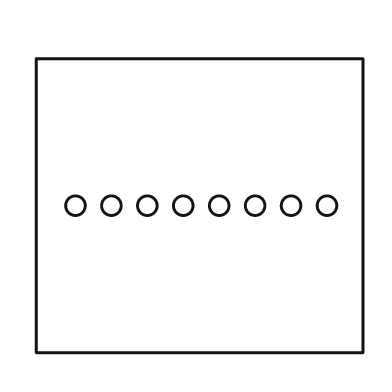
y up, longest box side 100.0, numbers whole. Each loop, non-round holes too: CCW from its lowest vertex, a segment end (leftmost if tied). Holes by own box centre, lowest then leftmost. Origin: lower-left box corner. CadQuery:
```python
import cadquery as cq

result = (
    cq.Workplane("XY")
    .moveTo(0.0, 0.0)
    .lineTo(100.0, 0.0)
    .lineTo(100.0, 90.0)
    .lineTo(0.0, 90.0)
    .close()
    .moveTo(12.0, 45.0)
    .circle(3.0)
    .moveTo(23.0, 45.0)
    .circle(3.0)
    .moveTo(34.0, 45.0)
    .circle(3.0)
    .moveTo(45.0, 45.0)
    .circle(3.0)
    .moveTo(56.0, 45.0)
    .circle(3.0)
    .moveTo(67.0, 45.0)
    .circle(3.0)
    .moveTo(78.0, 45.0)
    .circle(3.0)
    .moveTo(89.0, 45.0)
    .circle(3.0)
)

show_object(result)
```